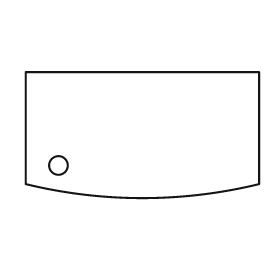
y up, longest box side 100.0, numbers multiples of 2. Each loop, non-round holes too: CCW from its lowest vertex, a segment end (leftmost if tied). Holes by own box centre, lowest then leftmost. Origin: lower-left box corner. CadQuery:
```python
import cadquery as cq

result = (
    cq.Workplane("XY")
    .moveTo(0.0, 6.0)
    .threePointArc((50.0, 0.0), (100.0, 6.0))
    .lineTo(100.0, 54.0)
    .lineTo(0.0, 54.0)
    .close()
    .moveTo(14.0, 14.0)
    .circle(4.0)
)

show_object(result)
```